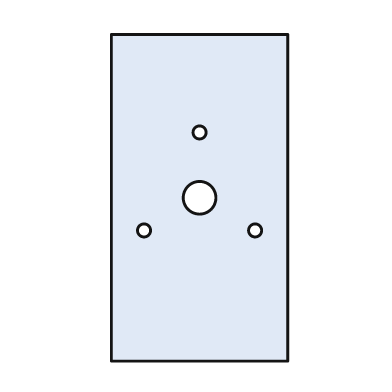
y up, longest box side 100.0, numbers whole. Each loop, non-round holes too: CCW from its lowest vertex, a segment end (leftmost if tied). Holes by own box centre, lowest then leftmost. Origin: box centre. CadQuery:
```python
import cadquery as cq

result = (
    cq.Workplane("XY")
    .moveTo(-27.0, -50.0)
    .lineTo(27.0, -50.0)
    .lineTo(27.0, 50.0)
    .lineTo(-27.0, 50.0)
    .close()
    .moveTo(-17.0, -10.0)
    .circle(2.0)
    .moveTo(17.0, -10.0)
    .circle(2.0)
    .moveTo(0.0, 0.0)
    .circle(5.0)
    .moveTo(0.0, 20.0)
    .circle(2.0)
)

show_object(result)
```